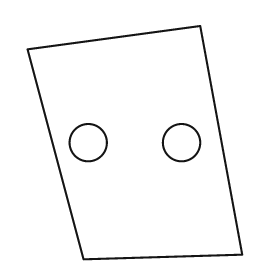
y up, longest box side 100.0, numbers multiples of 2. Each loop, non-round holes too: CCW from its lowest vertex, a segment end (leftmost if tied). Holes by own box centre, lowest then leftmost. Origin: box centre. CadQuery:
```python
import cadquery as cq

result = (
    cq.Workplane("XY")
    .moveTo(-22.0, -50.0)
    .lineTo(46.0, -48.0)
    .lineTo(28.0, 50.0)
    .lineTo(-46.0, 40.0)
    .close()
    .moveTo(-20.0, 0.0)
    .circle(8.0)
    .moveTo(20.0, 0.0)
    .circle(8.0)
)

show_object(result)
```